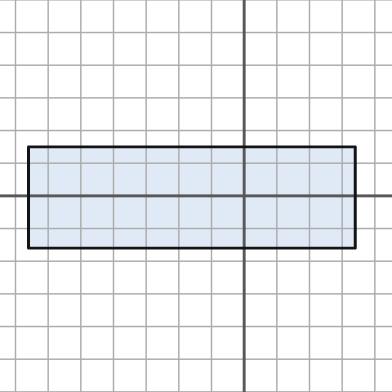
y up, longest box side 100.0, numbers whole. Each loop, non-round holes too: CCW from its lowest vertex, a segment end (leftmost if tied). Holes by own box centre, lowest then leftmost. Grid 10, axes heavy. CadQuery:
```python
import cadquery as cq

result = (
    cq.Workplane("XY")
    .moveTo(-66.0, -16.0)
    .lineTo(34.0, -16.0)
    .lineTo(34.0, 15.0)
    .lineTo(-66.0, 15.0)
    .close()
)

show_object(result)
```